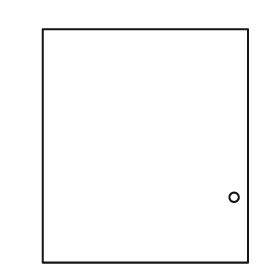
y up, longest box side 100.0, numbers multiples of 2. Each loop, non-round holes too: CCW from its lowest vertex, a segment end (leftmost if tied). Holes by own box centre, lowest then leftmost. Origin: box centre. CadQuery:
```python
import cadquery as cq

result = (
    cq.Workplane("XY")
    .moveTo(-44.0, -50.0)
    .lineTo(44.0, -50.0)
    .lineTo(44.0, 50.0)
    .lineTo(-44.0, 50.0)
    .close()
    .moveTo(38.0, -22.0)
    .circle(2.0)
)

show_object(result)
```